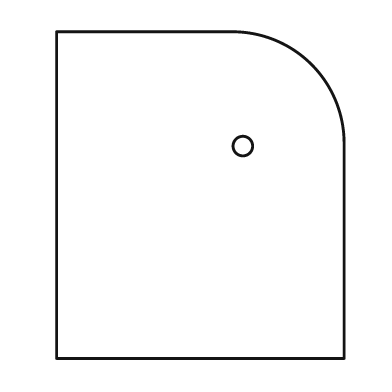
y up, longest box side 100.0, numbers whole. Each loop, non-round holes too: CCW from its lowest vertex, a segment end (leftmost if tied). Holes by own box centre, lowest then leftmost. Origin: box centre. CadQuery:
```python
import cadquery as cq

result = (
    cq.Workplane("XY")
    .moveTo(-44.0, -50.0)
    .lineTo(44.0, -50.0)
    .lineTo(44.0, 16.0)
    .threePointArc((34.0, 40.0), (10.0, 50.0))
    .lineTo(-44.0, 50.0)
    .close()
    .moveTo(13.0, 15.0)
    .circle(3.0)
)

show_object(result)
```